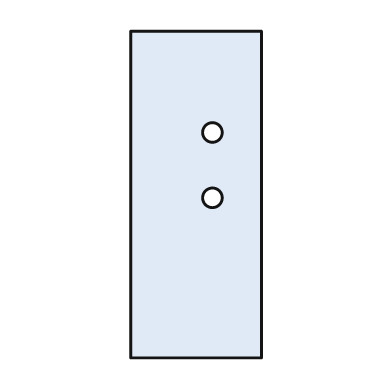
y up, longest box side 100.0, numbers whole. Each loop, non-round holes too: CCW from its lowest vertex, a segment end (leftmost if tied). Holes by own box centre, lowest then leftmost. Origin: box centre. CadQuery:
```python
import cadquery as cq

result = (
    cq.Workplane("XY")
    .moveTo(-20.0, -50.0)
    .lineTo(20.0, -50.0)
    .lineTo(20.0, 50.0)
    .lineTo(-20.0, 50.0)
    .close()
    .moveTo(5.0, -1.0)
    .circle(3.0)
    .moveTo(5.0, 19.0)
    .circle(3.0)
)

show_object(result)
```